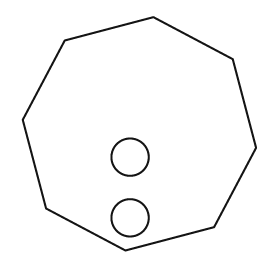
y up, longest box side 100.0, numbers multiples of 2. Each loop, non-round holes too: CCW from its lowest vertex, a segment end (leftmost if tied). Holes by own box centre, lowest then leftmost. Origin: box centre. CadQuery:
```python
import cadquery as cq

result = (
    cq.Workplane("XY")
    .moveTo(-6.0, -50.0)
    .lineTo(32.0, -40.0)
    .lineTo(50.0, -6.0)
    .lineTo(40.0, 32.0)
    .lineTo(6.0, 50.0)
    .lineTo(-32.0, 40.0)
    .lineTo(-50.0, 6.0)
    .lineTo(-40.0, -32.0)
    .close()
    .moveTo(-4.0, -36.0)
    .circle(8.0)
    .moveTo(-4.0, -10.0)
    .circle(8.0)
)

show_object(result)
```